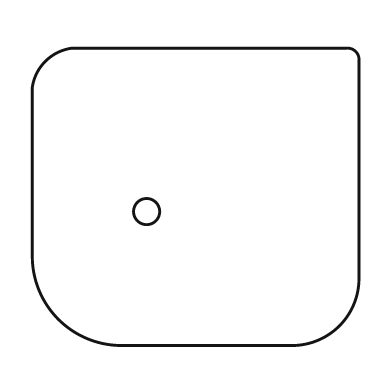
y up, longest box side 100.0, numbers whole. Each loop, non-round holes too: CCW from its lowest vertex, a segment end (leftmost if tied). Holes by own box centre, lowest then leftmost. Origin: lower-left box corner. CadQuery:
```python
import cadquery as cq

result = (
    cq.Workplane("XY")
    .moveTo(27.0, 0.0)
    .lineTo(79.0, 0.0)
    .threePointArc((94.0, 6.0), (100.0, 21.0))
    .lineTo(100.0, 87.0)
    .threePointArc((99.0, 90.0), (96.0, 91.0))
    .lineTo(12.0, 91.0)
    .threePointArc((4.0, 87.0), (0.0, 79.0))
    .lineTo(0.0, 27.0)
    .threePointArc((8.0, 8.0), (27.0, 0.0))
    .close()
    .moveTo(35.0, 41.0)
    .circle(4.0)
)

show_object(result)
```